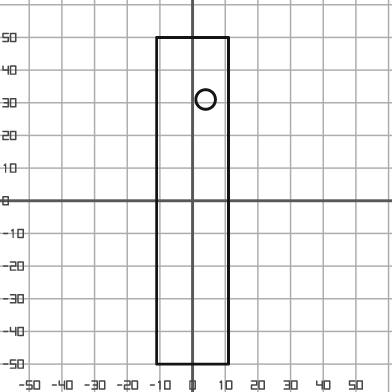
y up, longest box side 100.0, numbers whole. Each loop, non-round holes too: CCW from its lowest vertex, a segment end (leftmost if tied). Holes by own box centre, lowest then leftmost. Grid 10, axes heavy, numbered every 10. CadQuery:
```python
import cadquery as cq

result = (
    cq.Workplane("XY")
    .moveTo(-11.0, -50.0)
    .lineTo(11.0, -50.0)
    .lineTo(11.0, 50.0)
    .lineTo(-11.0, 50.0)
    .close()
    .moveTo(4.0, 31.0)
    .circle(3.0)
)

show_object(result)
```